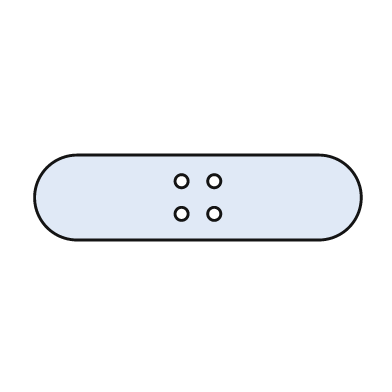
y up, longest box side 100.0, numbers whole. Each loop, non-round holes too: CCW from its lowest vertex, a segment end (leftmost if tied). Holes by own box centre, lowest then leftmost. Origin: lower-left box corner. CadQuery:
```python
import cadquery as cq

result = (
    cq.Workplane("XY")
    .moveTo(13.0, 0.0)
    .lineTo(87.0, 0.0)
    .threePointArc((100.0, 13.0), (87.0, 26.0))
    .lineTo(13.0, 26.0)
    .threePointArc((0.0, 13.0), (13.0, 0.0))
    .close()
    .moveTo(45.0, 8.0)
    .circle(2.0)
    .moveTo(55.0, 8.0)
    .circle(2.0)
    .moveTo(45.0, 18.0)
    .circle(2.0)
    .moveTo(55.0, 18.0)
    .circle(2.0)
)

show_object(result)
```